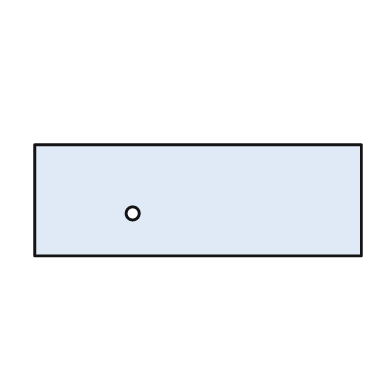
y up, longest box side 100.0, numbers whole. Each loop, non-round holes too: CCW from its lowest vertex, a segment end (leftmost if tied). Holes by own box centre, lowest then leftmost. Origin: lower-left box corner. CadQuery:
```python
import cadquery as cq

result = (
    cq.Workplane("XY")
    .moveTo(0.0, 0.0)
    .lineTo(100.0, 0.0)
    .lineTo(100.0, 34.0)
    .lineTo(0.0, 34.0)
    .close()
    .moveTo(30.0, 13.0)
    .circle(2.0)
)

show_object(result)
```